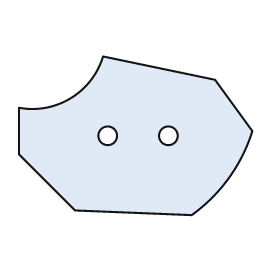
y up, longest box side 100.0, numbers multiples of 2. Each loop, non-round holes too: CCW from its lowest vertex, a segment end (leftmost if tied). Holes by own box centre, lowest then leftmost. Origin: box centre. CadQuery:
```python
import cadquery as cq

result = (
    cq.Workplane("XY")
    .moveTo(24.0, -34.0)
    .threePointArc((40.0, -18.0), (50.0, 2.0))
    .lineTo(34.0, 24.0)
    .lineTo(-14.0, 34.0)
    .threePointArc((-28.0, 16.0), (-50.0, 12.0))
    .lineTo(-50.0, -8.0)
    .lineTo(-26.0, -32.0)
    .close()
    .moveTo(-12.0, 0.0)
    .circle(4.0)
    .moveTo(14.0, 0.0)
    .circle(4.0)
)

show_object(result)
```